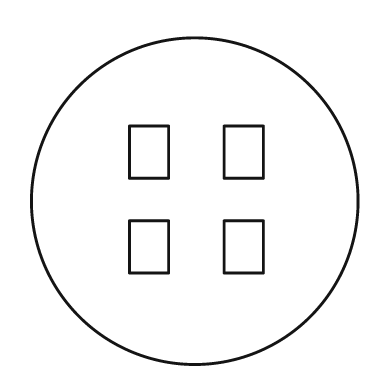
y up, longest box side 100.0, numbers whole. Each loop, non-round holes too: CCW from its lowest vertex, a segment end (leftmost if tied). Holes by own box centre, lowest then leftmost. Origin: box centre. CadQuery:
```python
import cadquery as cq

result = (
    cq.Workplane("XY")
    .moveTo(0.0, 0.0)
    .circle(50.0)
    .moveTo(-20.0, -22.0)
    .lineTo(-8.0, -22.0)
    .lineTo(-8.0, -6.0)
    .lineTo(-20.0, -6.0)
    .close()
    .moveTo(9.0, -22.0)
    .lineTo(21.0, -22.0)
    .lineTo(21.0, -6.0)
    .lineTo(9.0, -6.0)
    .close()
    .moveTo(-20.0, 7.0)
    .lineTo(-8.0, 7.0)
    .lineTo(-8.0, 23.0)
    .lineTo(-20.0, 23.0)
    .close()
    .moveTo(9.0, 7.0)
    .lineTo(21.0, 7.0)
    .lineTo(21.0, 23.0)
    .lineTo(9.0, 23.0)
    .close()
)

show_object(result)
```